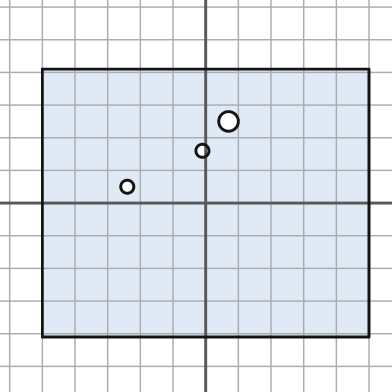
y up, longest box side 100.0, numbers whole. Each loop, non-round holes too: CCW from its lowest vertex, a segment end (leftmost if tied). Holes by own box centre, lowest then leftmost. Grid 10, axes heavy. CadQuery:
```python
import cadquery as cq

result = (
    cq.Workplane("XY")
    .moveTo(-50.0, -41.0)
    .lineTo(50.0, -41.0)
    .lineTo(50.0, 41.0)
    .lineTo(-50.0, 41.0)
    .close()
    .moveTo(-24.0, 5.0)
    .circle(2.0)
    .moveTo(-1.0, 16.0)
    .circle(2.0)
    .moveTo(7.0, 25.0)
    .circle(3.0)
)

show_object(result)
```